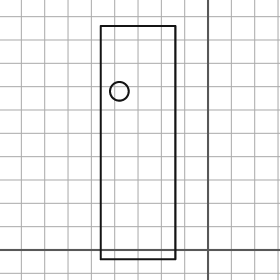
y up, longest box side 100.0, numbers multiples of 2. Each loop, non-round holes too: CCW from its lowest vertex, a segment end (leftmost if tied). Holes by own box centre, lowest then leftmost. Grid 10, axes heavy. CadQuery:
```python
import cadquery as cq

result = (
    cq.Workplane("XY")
    .moveTo(-46.0, -4.0)
    .lineTo(-14.0, -4.0)
    .lineTo(-14.0, 96.0)
    .lineTo(-46.0, 96.0)
    .close()
    .moveTo(-38.0, 68.0)
    .circle(4.0)
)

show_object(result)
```